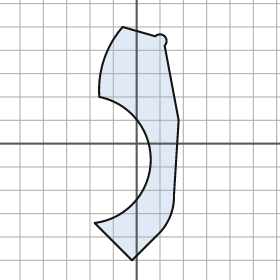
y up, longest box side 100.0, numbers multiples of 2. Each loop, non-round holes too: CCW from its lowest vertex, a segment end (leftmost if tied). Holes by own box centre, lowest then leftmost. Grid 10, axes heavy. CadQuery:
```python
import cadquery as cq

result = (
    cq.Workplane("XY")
    .moveTo(-2.0, -50.0)
    .lineTo(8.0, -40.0)
    .threePointArc((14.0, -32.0), (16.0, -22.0))
    .lineTo(18.0, 10.0)
    .lineTo(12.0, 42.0)
    .threePointArc((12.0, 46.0), (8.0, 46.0))
    .lineTo(-6.0, 50.0)
    .threePointArc((-14.0, 36.0), (-16.0, 20.0))
    .threePointArc((6.0, -8.0), (-18.0, -34.0))
    .close()
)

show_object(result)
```